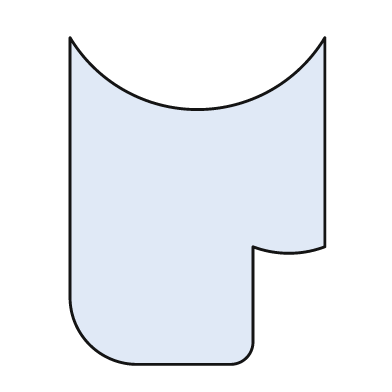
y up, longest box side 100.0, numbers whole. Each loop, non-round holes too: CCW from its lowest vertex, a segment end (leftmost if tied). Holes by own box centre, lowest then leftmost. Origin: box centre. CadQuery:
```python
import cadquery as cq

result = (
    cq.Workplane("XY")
    .moveTo(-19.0, -50.0)
    .lineTo(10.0, -50.0)
    .threePointArc((15.0, -48.0), (17.0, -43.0))
    .lineTo(17.0, -14.0)
    .threePointArc((28.0, -16.0), (39.0, -14.0))
    .lineTo(39.0, 50.0)
    .threePointArc((0.0, 28.0), (-39.0, 50.0))
    .lineTo(-39.0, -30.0)
    .threePointArc((-33.0, -44.0), (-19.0, -50.0))
    .close()
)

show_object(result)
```